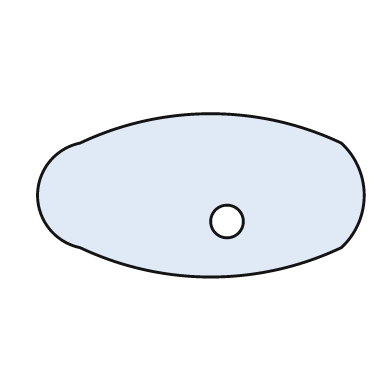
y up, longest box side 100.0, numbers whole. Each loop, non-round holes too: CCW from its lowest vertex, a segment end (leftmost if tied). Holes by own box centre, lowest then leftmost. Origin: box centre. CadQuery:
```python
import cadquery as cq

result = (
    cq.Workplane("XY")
    .moveTo(-37.0, -16.0)
    .threePointArc((3.0, -25.0), (43.0, -16.0))
    .threePointArc((50.0, 0.0), (43.0, 16.0))
    .threePointArc((3.0, 25.0), (-37.0, 16.0))
    .threePointArc((-50.0, 0.0), (-37.0, -16.0))
    .close()
    .moveTo(8.0, -8.0)
    .circle(5.0)
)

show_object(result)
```